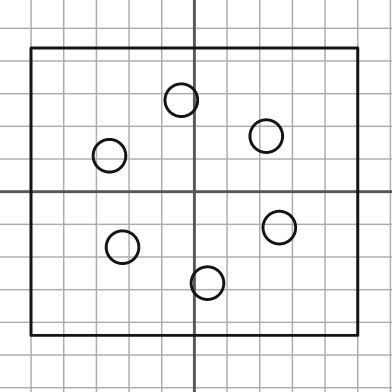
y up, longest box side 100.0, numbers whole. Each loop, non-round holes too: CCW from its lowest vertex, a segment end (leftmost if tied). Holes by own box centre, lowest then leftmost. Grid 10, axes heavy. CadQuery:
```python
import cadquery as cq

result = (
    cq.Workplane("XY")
    .moveTo(-50.0, -44.0)
    .lineTo(50.0, -44.0)
    .lineTo(50.0, 44.0)
    .lineTo(-50.0, 44.0)
    .close()
    .moveTo(4.0, -28.0)
    .circle(5.0)
    .moveTo(-22.0, -17.0)
    .circle(5.0)
    .moveTo(26.0, -11.0)
    .circle(5.0)
    .moveTo(-26.0, 11.0)
    .circle(5.0)
    .moveTo(22.0, 17.0)
    .circle(5.0)
    .moveTo(-4.0, 28.0)
    .circle(5.0)
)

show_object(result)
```